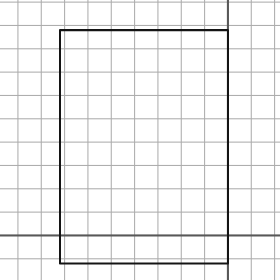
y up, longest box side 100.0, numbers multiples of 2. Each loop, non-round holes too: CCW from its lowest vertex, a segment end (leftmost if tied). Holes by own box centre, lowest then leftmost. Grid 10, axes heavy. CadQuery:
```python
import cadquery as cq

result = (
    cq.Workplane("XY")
    .moveTo(-72.0, -12.0)
    .lineTo(0.0, -12.0)
    .lineTo(0.0, 88.0)
    .lineTo(-72.0, 88.0)
    .close()
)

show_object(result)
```